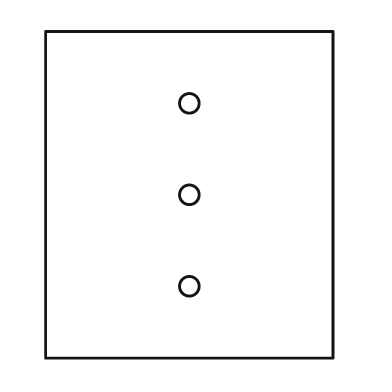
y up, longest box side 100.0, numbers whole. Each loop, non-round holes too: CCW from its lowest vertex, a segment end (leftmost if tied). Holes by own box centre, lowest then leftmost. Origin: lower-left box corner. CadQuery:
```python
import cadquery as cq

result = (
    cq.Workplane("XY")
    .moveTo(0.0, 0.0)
    .lineTo(88.0, 0.0)
    .lineTo(88.0, 100.0)
    .lineTo(0.0, 100.0)
    .close()
    .moveTo(44.0, 22.0)
    .circle(3.0)
    .moveTo(44.0, 50.0)
    .circle(3.0)
    .moveTo(44.0, 78.0)
    .circle(3.0)
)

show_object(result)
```